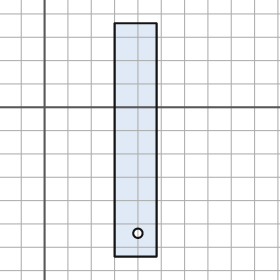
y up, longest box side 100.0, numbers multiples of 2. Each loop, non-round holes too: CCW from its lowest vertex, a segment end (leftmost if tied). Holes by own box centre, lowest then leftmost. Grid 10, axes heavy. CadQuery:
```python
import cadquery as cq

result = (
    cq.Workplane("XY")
    .moveTo(30.0, -64.0)
    .lineTo(48.0, -64.0)
    .lineTo(48.0, 36.0)
    .lineTo(30.0, 36.0)
    .close()
    .moveTo(40.0, -54.0)
    .circle(2.0)
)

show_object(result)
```